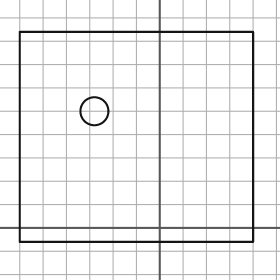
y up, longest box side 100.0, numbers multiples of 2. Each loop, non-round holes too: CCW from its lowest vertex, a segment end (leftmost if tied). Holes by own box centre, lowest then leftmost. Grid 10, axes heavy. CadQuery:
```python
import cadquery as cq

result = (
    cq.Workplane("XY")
    .moveTo(-60.0, -6.0)
    .lineTo(40.0, -6.0)
    .lineTo(40.0, 84.0)
    .lineTo(-60.0, 84.0)
    .close()
    .moveTo(-28.0, 50.0)
    .circle(6.0)
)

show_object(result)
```